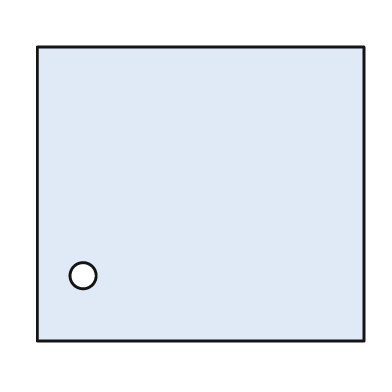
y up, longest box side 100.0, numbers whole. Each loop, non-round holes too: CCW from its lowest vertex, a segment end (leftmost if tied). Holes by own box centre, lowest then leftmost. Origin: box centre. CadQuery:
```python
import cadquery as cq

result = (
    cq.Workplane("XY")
    .moveTo(-50.0, -45.0)
    .lineTo(50.0, -45.0)
    .lineTo(50.0, 45.0)
    .lineTo(-50.0, 45.0)
    .close()
    .moveTo(-36.0, -25.0)
    .circle(4.0)
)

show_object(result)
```